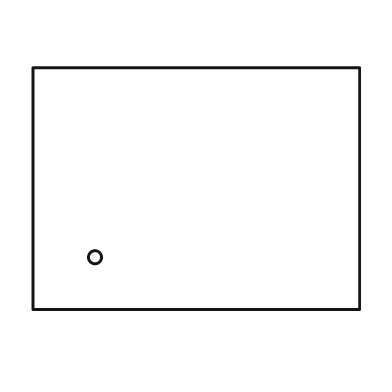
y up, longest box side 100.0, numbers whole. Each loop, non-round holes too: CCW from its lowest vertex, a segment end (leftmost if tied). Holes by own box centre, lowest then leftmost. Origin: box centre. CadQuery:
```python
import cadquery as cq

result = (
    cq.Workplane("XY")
    .moveTo(-50.0, -37.0)
    .lineTo(50.0, -37.0)
    .lineTo(50.0, 37.0)
    .lineTo(-50.0, 37.0)
    .close()
    .moveTo(-31.0, -21.0)
    .circle(2.0)
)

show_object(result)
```